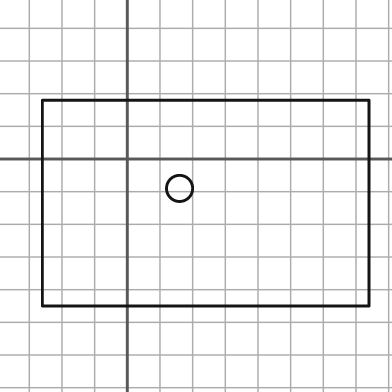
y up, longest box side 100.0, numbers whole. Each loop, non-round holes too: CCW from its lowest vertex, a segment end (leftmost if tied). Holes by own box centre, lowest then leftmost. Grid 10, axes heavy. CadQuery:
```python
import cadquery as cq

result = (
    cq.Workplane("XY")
    .moveTo(-26.0, -45.0)
    .lineTo(74.0, -45.0)
    .lineTo(74.0, 18.0)
    .lineTo(-26.0, 18.0)
    .close()
    .moveTo(16.0, -9.0)
    .circle(4.0)
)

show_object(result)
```